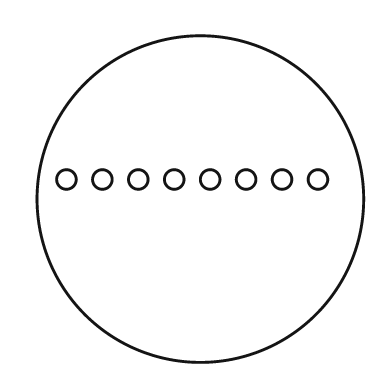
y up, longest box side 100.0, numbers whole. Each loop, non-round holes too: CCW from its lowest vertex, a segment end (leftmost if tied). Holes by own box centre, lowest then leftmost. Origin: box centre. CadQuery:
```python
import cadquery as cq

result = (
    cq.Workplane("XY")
    .moveTo(0.0, 0.0)
    .circle(50.0)
    .moveTo(-41.0, 6.0)
    .circle(3.0)
    .moveTo(-30.0, 6.0)
    .circle(3.0)
    .moveTo(-19.0, 6.0)
    .circle(3.0)
    .moveTo(-8.0, 6.0)
    .circle(3.0)
    .moveTo(3.0, 6.0)
    .circle(3.0)
    .moveTo(14.0, 6.0)
    .circle(3.0)
    .moveTo(25.0, 6.0)
    .circle(3.0)
    .moveTo(36.0, 6.0)
    .circle(3.0)
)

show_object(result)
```